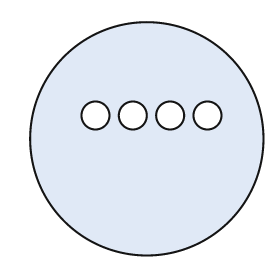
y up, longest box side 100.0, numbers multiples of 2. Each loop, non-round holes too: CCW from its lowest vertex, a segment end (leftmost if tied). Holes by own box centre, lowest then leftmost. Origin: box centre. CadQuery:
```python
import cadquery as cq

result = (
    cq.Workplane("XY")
    .moveTo(0.0, 0.0)
    .circle(50.0)
    .moveTo(-22.0, 10.0)
    .circle(6.0)
    .moveTo(-6.0, 10.0)
    .circle(6.0)
    .moveTo(10.0, 10.0)
    .circle(6.0)
    .moveTo(26.0, 10.0)
    .circle(6.0)
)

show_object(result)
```